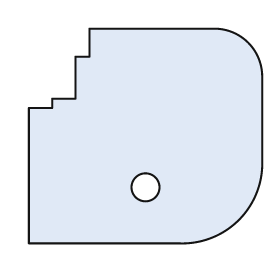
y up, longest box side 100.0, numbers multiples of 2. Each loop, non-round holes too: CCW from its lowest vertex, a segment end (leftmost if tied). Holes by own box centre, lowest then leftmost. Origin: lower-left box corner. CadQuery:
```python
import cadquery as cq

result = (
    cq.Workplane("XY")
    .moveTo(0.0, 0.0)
    .lineTo(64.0, 0.0)
    .threePointArc((90.0, 10.0), (100.0, 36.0))
    .lineTo(100.0, 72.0)
    .threePointArc((94.0, 86.0), (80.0, 92.0))
    .lineTo(26.0, 92.0)
    .lineTo(26.0, 80.0)
    .lineTo(20.0, 80.0)
    .lineTo(20.0, 62.0)
    .lineTo(10.0, 62.0)
    .lineTo(10.0, 58.0)
    .lineTo(0.0, 58.0)
    .close()
    .moveTo(50.0, 24.0)
    .circle(6.0)
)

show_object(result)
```